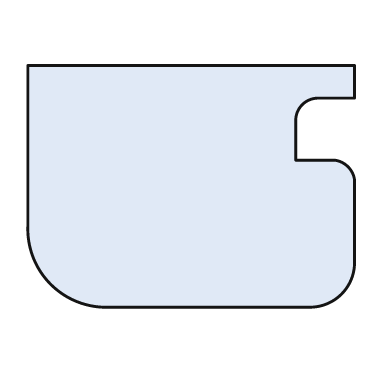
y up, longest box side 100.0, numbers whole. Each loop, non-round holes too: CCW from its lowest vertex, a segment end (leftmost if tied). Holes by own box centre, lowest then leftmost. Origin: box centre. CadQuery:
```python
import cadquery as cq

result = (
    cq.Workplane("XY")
    .moveTo(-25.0, -37.0)
    .lineTo(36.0, -37.0)
    .threePointArc((46.0, -33.0), (50.0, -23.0))
    .lineTo(50.0, 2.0)
    .threePointArc((48.0, 6.0), (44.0, 8.0))
    .lineTo(32.0, 8.0)
    .lineTo(32.0, 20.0)
    .threePointArc((34.0, 25.0), (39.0, 27.0))
    .lineTo(50.0, 27.0)
    .lineTo(50.0, 37.0)
    .lineTo(-50.0, 37.0)
    .lineTo(-50.0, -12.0)
    .threePointArc((-43.0, -30.0), (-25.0, -37.0))
    .close()
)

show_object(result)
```